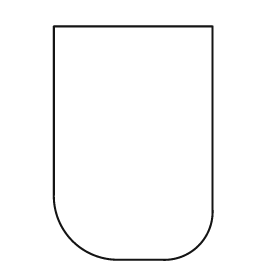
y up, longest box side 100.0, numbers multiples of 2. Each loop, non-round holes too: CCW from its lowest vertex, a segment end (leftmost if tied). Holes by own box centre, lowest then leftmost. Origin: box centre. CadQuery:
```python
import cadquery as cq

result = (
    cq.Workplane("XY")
    .moveTo(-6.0, -50.0)
    .lineTo(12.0, -50.0)
    .threePointArc((28.0, -44.0), (34.0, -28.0))
    .lineTo(34.0, 50.0)
    .lineTo(-34.0, 50.0)
    .lineTo(-34.0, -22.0)
    .threePointArc((-26.0, -42.0), (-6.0, -50.0))
    .close()
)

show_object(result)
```